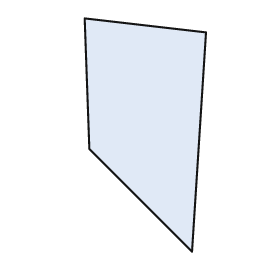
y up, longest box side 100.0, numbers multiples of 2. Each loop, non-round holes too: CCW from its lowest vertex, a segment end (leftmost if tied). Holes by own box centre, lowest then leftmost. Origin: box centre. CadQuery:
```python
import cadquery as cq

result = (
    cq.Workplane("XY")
    .moveTo(20.0, -50.0)
    .lineTo(26.0, 44.0)
    .lineTo(-26.0, 50.0)
    .lineTo(-24.0, -6.0)
    .close()
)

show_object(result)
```